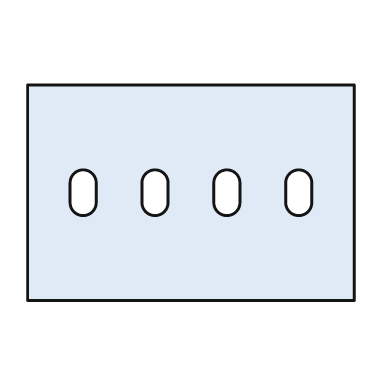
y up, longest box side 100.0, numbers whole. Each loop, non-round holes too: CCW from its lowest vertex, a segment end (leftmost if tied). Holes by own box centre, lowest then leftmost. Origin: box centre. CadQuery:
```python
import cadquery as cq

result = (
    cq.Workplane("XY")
    .moveTo(-50.0, -33.0)
    .lineTo(50.0, -33.0)
    .lineTo(50.0, 33.0)
    .lineTo(-50.0, 33.0)
    .close()
    .moveTo(-37.0, -3.0)
    .threePointArc((-33.0, -7.0), (-29.0, -3.0))
    .lineTo(-29.0, 3.0)
    .threePointArc((-33.0, 7.0), (-37.0, 3.0))
    .close()
    .moveTo(-15.0, -3.0)
    .threePointArc((-11.0, -7.0), (-7.0, -3.0))
    .lineTo(-7.0, 3.0)
    .threePointArc((-11.0, 7.0), (-15.0, 3.0))
    .close()
    .moveTo(7.0, -3.0)
    .threePointArc((11.0, -7.0), (15.0, -3.0))
    .lineTo(15.0, 3.0)
    .threePointArc((11.0, 7.0), (7.0, 3.0))
    .close()
    .moveTo(29.0, -3.0)
    .threePointArc((33.0, -7.0), (37.0, -3.0))
    .lineTo(37.0, 3.0)
    .threePointArc((33.0, 7.0), (29.0, 3.0))
    .close()
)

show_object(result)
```